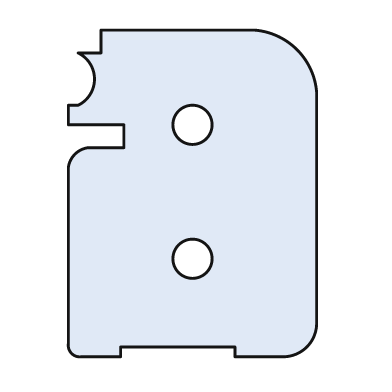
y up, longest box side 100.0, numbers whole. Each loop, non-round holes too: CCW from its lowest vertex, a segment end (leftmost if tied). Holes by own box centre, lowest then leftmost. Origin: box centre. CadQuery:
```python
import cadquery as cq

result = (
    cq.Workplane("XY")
    .moveTo(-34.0, -50.0)
    .lineTo(-22.0, -50.0)
    .lineTo(-22.0, -47.0)
    .lineTo(13.0, -47.0)
    .lineTo(13.0, -50.0)
    .lineTo(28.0, -50.0)
    .threePointArc((35.0, -47.0), (38.0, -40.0))
    .lineTo(38.0, 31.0)
    .threePointArc((32.0, 44.0), (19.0, 50.0))
    .lineTo(-28.0, 50.0)
    .lineTo(-28.0, 43.0)
    .lineTo(-35.0, 43.0)
    .threePointArc((-30.0, 35.0), (-35.0, 27.0))
    .lineTo(-38.0, 27.0)
    .lineTo(-38.0, 21.0)
    .lineTo(-21.0, 21.0)
    .lineTo(-21.0, 14.0)
    .lineTo(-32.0, 14.0)
    .threePointArc((-36.0, 12.0), (-38.0, 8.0))
    .lineTo(-38.0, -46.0)
    .threePointArc((-37.0, -49.0), (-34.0, -50.0))
    .close()
    .moveTo(0.0, -20.0)
    .circle(6.0)
    .moveTo(0.0, 21.0)
    .circle(6.0)
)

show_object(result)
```